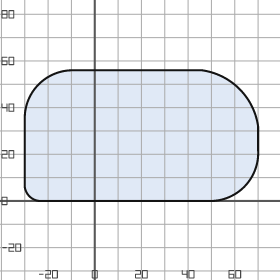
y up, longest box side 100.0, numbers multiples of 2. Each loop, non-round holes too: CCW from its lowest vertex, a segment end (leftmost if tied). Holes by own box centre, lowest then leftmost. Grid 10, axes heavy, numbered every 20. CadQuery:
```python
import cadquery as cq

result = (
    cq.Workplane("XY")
    .moveTo(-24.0, 0.0)
    .lineTo(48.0, 0.0)
    .threePointArc((64.0, 6.0), (70.0, 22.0))
    .lineTo(70.0, 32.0)
    .threePointArc((62.0, 48.0), (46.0, 56.0))
    .lineTo(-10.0, 56.0)
    .threePointArc((-24.0, 50.0), (-30.0, 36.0))
    .lineTo(-30.0, 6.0)
    .threePointArc((-28.0, 2.0), (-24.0, 0.0))
    .close()
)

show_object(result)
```